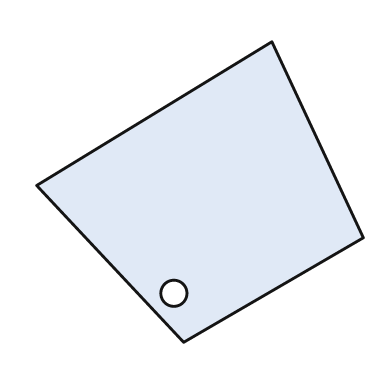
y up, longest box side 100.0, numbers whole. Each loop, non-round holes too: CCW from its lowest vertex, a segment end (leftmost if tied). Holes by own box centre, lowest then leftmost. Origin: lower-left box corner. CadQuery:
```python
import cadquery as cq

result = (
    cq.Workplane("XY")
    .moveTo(45.0, 0.0)
    .lineTo(100.0, 32.0)
    .lineTo(72.0, 92.0)
    .lineTo(0.0, 48.0)
    .close()
    .moveTo(42.0, 15.0)
    .circle(4.0)
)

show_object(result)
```